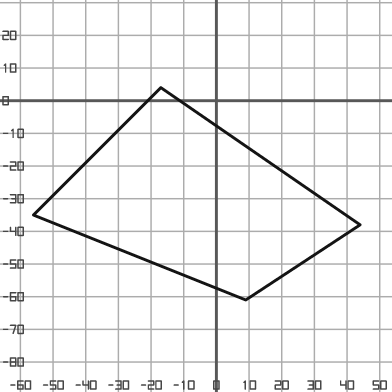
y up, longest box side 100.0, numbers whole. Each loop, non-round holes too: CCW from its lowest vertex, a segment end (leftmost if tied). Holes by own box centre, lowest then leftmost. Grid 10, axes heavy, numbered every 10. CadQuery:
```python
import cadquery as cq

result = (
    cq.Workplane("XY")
    .moveTo(9.0, -61.0)
    .lineTo(44.0, -38.0)
    .lineTo(-17.0, 4.0)
    .lineTo(-56.0, -35.0)
    .close()
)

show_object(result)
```